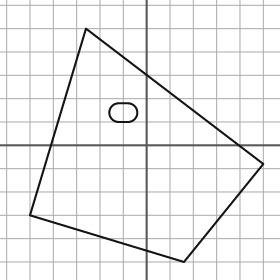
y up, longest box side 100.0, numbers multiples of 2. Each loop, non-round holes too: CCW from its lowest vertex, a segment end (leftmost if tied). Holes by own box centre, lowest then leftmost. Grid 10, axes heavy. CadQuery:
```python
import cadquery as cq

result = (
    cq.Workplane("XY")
    .moveTo(16.0, -50.0)
    .lineTo(50.0, -8.0)
    .lineTo(-26.0, 50.0)
    .lineTo(-50.0, -30.0)
    .close()
    .moveTo(-12.0, 10.0)
    .lineTo(-8.0, 10.0)
    .threePointArc((-4.0, 14.0), (-8.0, 18.0))
    .lineTo(-12.0, 18.0)
    .threePointArc((-16.0, 14.0), (-12.0, 10.0))
    .close()
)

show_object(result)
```